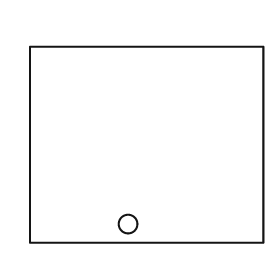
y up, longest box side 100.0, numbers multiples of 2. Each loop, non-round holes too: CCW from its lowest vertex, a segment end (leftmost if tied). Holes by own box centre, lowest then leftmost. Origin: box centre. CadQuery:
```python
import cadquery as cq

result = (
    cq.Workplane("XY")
    .moveTo(-50.0, -42.0)
    .lineTo(50.0, -42.0)
    .lineTo(50.0, 42.0)
    .lineTo(-50.0, 42.0)
    .close()
    .moveTo(-8.0, -34.0)
    .circle(4.0)
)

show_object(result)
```